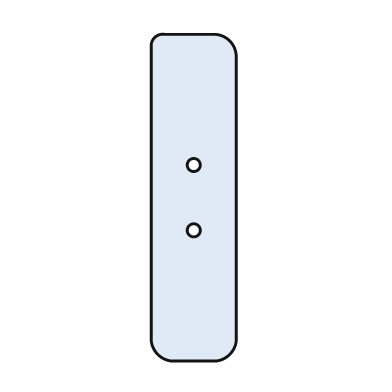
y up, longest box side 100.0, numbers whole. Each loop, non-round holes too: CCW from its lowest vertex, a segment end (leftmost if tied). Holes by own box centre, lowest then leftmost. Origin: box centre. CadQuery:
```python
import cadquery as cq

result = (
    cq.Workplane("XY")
    .moveTo(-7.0, -50.0)
    .lineTo(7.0, -50.0)
    .threePointArc((11.0, -48.0), (13.0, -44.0))
    .lineTo(13.0, 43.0)
    .threePointArc((11.0, 48.0), (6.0, 50.0))
    .lineTo(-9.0, 50.0)
    .threePointArc((-12.0, 49.0), (-13.0, 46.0))
    .lineTo(-13.0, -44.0)
    .threePointArc((-11.0, -48.0), (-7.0, -50.0))
    .close()
    .moveTo(0.0, -10.0)
    .circle(2.0)
    .moveTo(0.0, 10.0)
    .circle(2.0)
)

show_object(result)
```